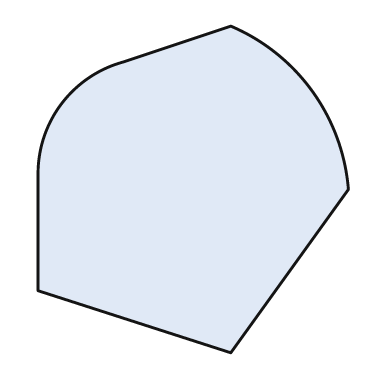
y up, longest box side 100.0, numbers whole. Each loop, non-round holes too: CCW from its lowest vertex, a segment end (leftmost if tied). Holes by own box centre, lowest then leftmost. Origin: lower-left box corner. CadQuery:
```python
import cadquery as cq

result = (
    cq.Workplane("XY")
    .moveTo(59.0, 0.0)
    .lineTo(95.0, 50.0)
    .threePointArc((84.0, 80.0), (59.0, 100.0))
    .lineTo(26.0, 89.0)
    .threePointArc((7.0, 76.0), (0.0, 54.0))
    .lineTo(0.0, 19.0)
    .close()
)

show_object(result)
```